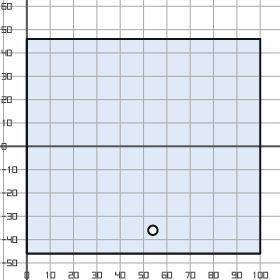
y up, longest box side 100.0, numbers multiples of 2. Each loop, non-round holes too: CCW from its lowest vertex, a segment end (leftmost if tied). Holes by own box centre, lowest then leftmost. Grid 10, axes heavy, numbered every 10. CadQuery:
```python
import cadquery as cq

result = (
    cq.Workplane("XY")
    .moveTo(0.0, -46.0)
    .lineTo(100.0, -46.0)
    .lineTo(100.0, 46.0)
    .lineTo(0.0, 46.0)
    .close()
    .moveTo(54.0, -36.0)
    .circle(2.0)
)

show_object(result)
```